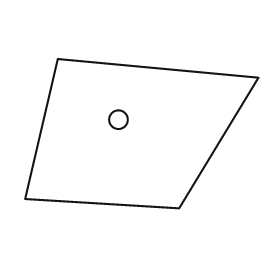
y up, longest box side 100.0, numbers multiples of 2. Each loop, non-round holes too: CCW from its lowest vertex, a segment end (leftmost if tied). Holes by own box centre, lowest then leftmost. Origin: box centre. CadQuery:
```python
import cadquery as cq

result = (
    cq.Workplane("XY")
    .moveTo(16.0, -32.0)
    .lineTo(50.0, 24.0)
    .lineTo(-36.0, 32.0)
    .lineTo(-50.0, -28.0)
    .close()
    .moveTo(-10.0, 6.0)
    .circle(4.0)
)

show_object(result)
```